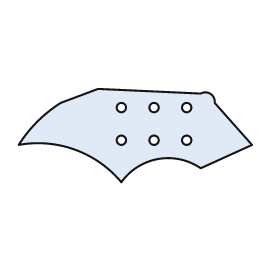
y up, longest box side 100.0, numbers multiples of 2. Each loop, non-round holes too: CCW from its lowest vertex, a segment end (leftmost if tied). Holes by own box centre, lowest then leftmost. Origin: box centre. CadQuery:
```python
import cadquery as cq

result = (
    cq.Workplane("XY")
    .moveTo(-6.0, -20.0)
    .threePointArc((10.0, -10.0), (28.0, -14.0))
    .lineTo(50.0, -4.0)
    .lineTo(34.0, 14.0)
    .threePointArc((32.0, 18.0), (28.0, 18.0))
    .lineTo(-16.0, 20.0)
    .lineTo(-32.0, 14.0)
    .threePointArc((-42.0, 6.0), (-50.0, -4.0))
    .threePointArc((-26.0, -6.0), (-6.0, -20.0))
    .close()
    .moveTo(-6.0, -2.0)
    .circle(2.0)
    .moveTo(8.0, -2.0)
    .circle(2.0)
    .moveTo(22.0, -2.0)
    .circle(2.0)
    .moveTo(-6.0, 12.0)
    .circle(2.0)
    .moveTo(8.0, 12.0)
    .circle(2.0)
    .moveTo(22.0, 12.0)
    .circle(2.0)
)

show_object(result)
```